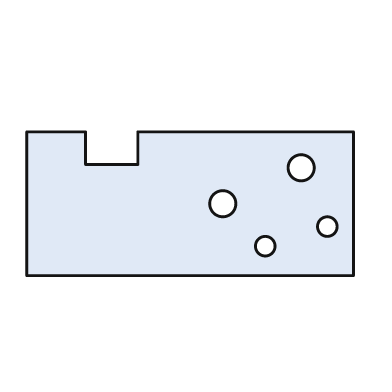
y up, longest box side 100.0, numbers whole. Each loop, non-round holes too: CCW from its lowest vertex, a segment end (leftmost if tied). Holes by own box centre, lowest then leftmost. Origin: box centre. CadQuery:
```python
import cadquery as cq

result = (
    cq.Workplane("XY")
    .moveTo(-50.0, -22.0)
    .lineTo(50.0, -22.0)
    .lineTo(50.0, 22.0)
    .lineTo(-16.0, 22.0)
    .lineTo(-16.0, 12.0)
    .lineTo(-32.0, 12.0)
    .lineTo(-32.0, 22.0)
    .lineTo(-50.0, 22.0)
    .close()
    .moveTo(23.0, -13.0)
    .circle(3.0)
    .moveTo(42.0, -7.0)
    .circle(3.0)
    .moveTo(10.0, 0.0)
    .circle(4.0)
    .moveTo(34.0, 11.0)
    .circle(4.0)
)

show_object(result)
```